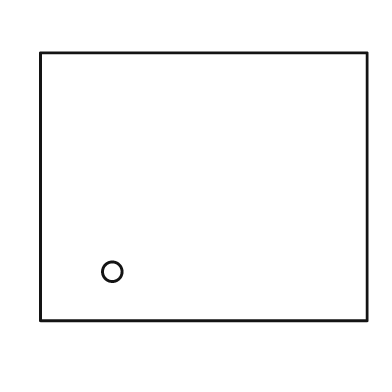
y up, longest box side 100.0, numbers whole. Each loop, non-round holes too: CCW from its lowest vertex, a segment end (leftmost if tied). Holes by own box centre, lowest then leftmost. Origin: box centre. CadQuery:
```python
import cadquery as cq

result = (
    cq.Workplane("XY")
    .moveTo(-50.0, -41.0)
    .lineTo(50.0, -41.0)
    .lineTo(50.0, 41.0)
    .lineTo(-50.0, 41.0)
    .close()
    .moveTo(-28.0, -26.0)
    .circle(3.0)
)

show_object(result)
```